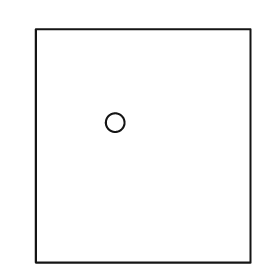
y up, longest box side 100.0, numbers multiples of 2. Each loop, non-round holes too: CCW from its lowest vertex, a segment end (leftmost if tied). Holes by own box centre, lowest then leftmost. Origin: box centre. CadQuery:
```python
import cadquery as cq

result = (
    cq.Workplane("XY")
    .moveTo(-46.0, -50.0)
    .lineTo(46.0, -50.0)
    .lineTo(46.0, 50.0)
    .lineTo(-46.0, 50.0)
    .close()
    .moveTo(-12.0, 10.0)
    .circle(4.0)
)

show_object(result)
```